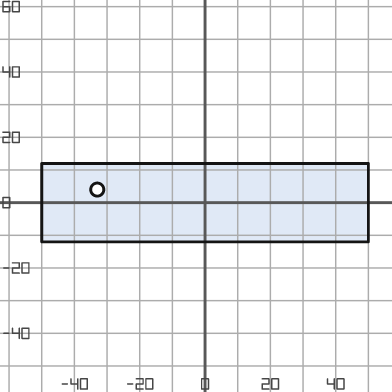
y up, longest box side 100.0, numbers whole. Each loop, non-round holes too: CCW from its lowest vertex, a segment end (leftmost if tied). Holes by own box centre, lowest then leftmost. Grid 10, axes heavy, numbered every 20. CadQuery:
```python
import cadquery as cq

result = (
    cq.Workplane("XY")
    .moveTo(-50.0, -12.0)
    .lineTo(50.0, -12.0)
    .lineTo(50.0, 12.0)
    .lineTo(-50.0, 12.0)
    .close()
    .moveTo(-33.0, 4.0)
    .circle(2.0)
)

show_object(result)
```